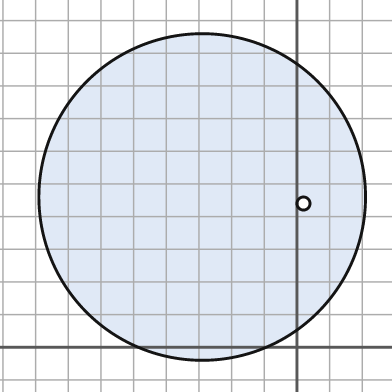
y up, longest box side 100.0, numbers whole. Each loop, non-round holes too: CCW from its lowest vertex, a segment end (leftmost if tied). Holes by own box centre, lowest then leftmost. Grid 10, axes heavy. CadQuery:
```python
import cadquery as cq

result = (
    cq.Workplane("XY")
    .moveTo(-29.0, 46.0)
    .circle(50.0)
    .moveTo(2.0, 44.0)
    .circle(2.0)
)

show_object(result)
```